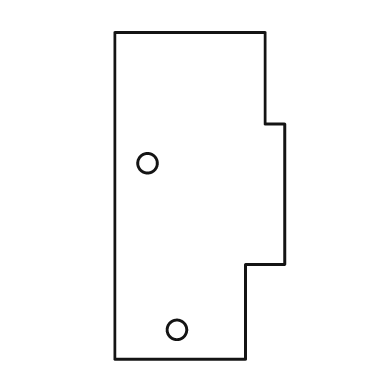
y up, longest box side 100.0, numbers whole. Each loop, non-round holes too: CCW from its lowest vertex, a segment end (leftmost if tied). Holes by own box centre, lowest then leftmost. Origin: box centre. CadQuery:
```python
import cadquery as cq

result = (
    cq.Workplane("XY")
    .moveTo(-26.0, -50.0)
    .lineTo(14.0, -50.0)
    .lineTo(14.0, -21.0)
    .lineTo(26.0, -21.0)
    .lineTo(26.0, 22.0)
    .lineTo(20.0, 22.0)
    .lineTo(20.0, 50.0)
    .lineTo(-26.0, 50.0)
    .close()
    .moveTo(-7.0, -41.0)
    .circle(3.0)
    .moveTo(-16.0, 10.0)
    .circle(3.0)
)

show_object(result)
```